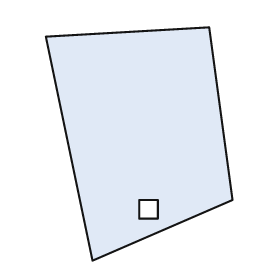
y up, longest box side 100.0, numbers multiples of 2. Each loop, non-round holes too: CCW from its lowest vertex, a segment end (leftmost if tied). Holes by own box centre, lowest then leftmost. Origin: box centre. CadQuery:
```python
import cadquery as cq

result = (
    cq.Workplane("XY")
    .moveTo(-20.0, -50.0)
    .lineTo(40.0, -24.0)
    .lineTo(30.0, 50.0)
    .lineTo(-40.0, 46.0)
    .close()
    .moveTo(0.0, -32.0)
    .lineTo(8.0, -32.0)
    .lineTo(8.0, -24.0)
    .lineTo(0.0, -24.0)
    .close()
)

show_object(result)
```